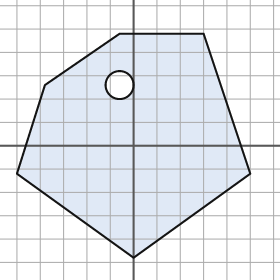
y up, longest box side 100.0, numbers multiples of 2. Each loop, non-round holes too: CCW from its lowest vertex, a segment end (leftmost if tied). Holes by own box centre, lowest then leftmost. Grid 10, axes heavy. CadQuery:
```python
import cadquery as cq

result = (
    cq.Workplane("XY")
    .moveTo(0.0, -48.0)
    .lineTo(50.0, -12.0)
    .lineTo(30.0, 48.0)
    .lineTo(-6.0, 48.0)
    .lineTo(-38.0, 26.0)
    .lineTo(-50.0, -12.0)
    .close()
    .moveTo(-6.0, 26.0)
    .circle(6.0)
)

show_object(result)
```